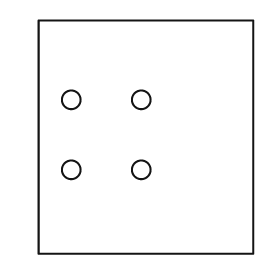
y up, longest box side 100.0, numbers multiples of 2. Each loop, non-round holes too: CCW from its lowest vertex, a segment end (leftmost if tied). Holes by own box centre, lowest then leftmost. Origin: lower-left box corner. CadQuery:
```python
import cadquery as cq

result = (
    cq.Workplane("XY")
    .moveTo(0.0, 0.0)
    .lineTo(92.0, 0.0)
    .lineTo(92.0, 100.0)
    .lineTo(0.0, 100.0)
    .close()
    .moveTo(14.0, 36.0)
    .circle(4.0)
    .moveTo(44.0, 36.0)
    .circle(4.0)
    .moveTo(14.0, 66.0)
    .circle(4.0)
    .moveTo(44.0, 66.0)
    .circle(4.0)
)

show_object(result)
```